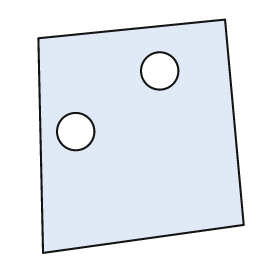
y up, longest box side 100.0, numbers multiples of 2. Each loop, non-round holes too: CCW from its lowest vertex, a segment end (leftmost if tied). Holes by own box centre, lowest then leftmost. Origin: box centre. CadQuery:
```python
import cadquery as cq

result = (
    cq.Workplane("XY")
    .moveTo(-42.0, -50.0)
    .lineTo(44.0, -38.0)
    .lineTo(36.0, 50.0)
    .lineTo(-44.0, 42.0)
    .close()
    .moveTo(-28.0, 2.0)
    .circle(8.0)
    .moveTo(8.0, 28.0)
    .circle(8.0)
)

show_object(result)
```